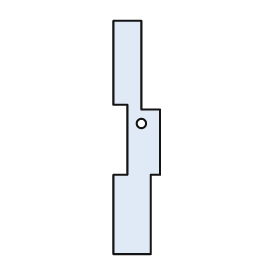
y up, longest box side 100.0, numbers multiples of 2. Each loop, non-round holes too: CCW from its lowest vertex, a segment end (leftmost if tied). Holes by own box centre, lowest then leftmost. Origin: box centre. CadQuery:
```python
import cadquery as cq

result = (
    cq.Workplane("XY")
    .moveTo(-10.0, -50.0)
    .lineTo(6.0, -50.0)
    .lineTo(6.0, -16.0)
    .lineTo(10.0, -16.0)
    .lineTo(10.0, 12.0)
    .lineTo(2.0, 12.0)
    .lineTo(2.0, 50.0)
    .lineTo(-10.0, 50.0)
    .lineTo(-10.0, 14.0)
    .lineTo(-4.0, 14.0)
    .lineTo(-4.0, -16.0)
    .lineTo(-10.0, -16.0)
    .close()
    .moveTo(2.0, 6.0)
    .circle(2.0)
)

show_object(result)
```